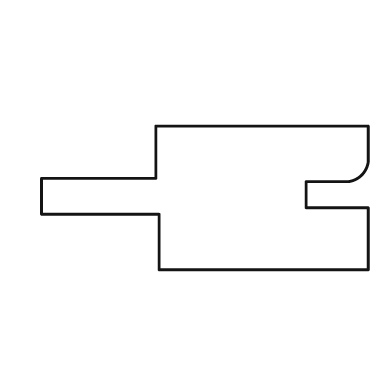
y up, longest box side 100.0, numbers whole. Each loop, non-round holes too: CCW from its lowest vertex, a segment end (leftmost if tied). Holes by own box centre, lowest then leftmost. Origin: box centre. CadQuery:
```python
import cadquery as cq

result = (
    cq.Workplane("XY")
    .moveTo(-14.0, -22.0)
    .lineTo(50.0, -22.0)
    .lineTo(50.0, -3.0)
    .lineTo(31.0, -3.0)
    .lineTo(31.0, 5.0)
    .lineTo(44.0, 5.0)
    .threePointArc((48.0, 7.0), (50.0, 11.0))
    .lineTo(50.0, 22.0)
    .lineTo(-15.0, 22.0)
    .lineTo(-15.0, 6.0)
    .lineTo(-50.0, 6.0)
    .lineTo(-50.0, -5.0)
    .lineTo(-14.0, -5.0)
    .close()
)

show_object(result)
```